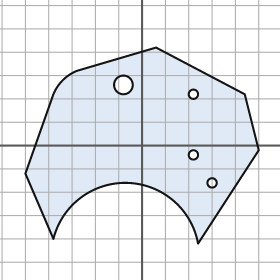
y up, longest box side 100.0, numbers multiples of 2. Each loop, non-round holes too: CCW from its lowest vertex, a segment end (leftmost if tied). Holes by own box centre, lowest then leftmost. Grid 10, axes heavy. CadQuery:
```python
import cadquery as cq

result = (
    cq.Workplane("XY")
    .moveTo(24.0, -42.0)
    .lineTo(50.0, -2.0)
    .lineTo(44.0, 22.0)
    .lineTo(6.0, 42.0)
    .lineTo(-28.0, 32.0)
    .threePointArc((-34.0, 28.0), (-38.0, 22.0))
    .lineTo(-50.0, -12.0)
    .lineTo(-38.0, -40.0)
    .threePointArc((-6.0, -16.0), (24.0, -42.0))
    .close()
    .moveTo(30.0, -16.0)
    .circle(2.0)
    .moveTo(22.0, -4.0)
    .circle(2.0)
    .moveTo(22.0, 22.0)
    .circle(2.0)
    .moveTo(-8.0, 26.0)
    .circle(4.0)
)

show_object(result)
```